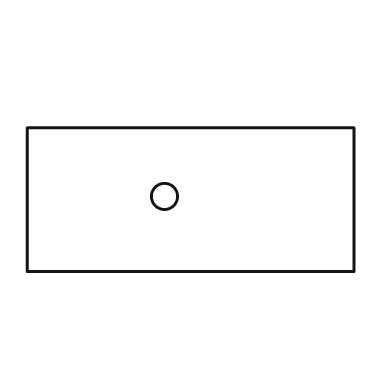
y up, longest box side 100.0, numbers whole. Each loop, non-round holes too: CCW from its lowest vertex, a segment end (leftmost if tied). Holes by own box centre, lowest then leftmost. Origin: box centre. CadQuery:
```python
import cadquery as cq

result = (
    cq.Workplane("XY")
    .moveTo(-50.0, -22.0)
    .lineTo(50.0, -22.0)
    .lineTo(50.0, 22.0)
    .lineTo(-50.0, 22.0)
    .close()
    .moveTo(-8.0, 1.0)
    .circle(4.0)
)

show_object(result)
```